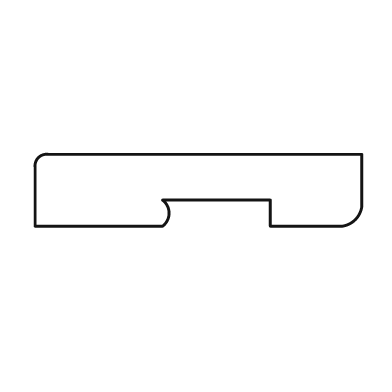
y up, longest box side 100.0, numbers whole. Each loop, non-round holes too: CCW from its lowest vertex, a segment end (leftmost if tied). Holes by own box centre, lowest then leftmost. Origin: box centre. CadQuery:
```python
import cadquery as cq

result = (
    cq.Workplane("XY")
    .moveTo(-50.0, -11.0)
    .lineTo(-11.0, -11.0)
    .threePointArc((-9.0, -7.0), (-11.0, -3.0))
    .lineTo(22.0, -3.0)
    .lineTo(22.0, -11.0)
    .lineTo(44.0, -11.0)
    .threePointArc((48.0, -9.0), (50.0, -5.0))
    .lineTo(50.0, 11.0)
    .lineTo(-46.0, 11.0)
    .threePointArc((-49.0, 10.0), (-50.0, 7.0))
    .close()
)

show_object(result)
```